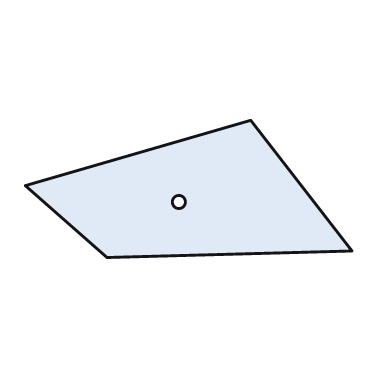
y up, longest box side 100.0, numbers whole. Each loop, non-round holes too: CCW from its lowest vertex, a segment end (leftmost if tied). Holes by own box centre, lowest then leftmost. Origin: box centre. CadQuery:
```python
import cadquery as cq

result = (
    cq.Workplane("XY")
    .moveTo(-25.0, -21.0)
    .lineTo(50.0, -19.0)
    .lineTo(19.0, 21.0)
    .lineTo(-50.0, 1.0)
    .close()
    .moveTo(-3.0, -4.0)
    .circle(2.0)
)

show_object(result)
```